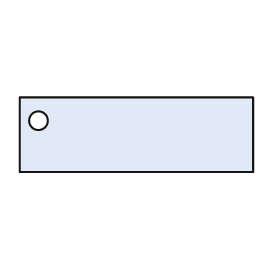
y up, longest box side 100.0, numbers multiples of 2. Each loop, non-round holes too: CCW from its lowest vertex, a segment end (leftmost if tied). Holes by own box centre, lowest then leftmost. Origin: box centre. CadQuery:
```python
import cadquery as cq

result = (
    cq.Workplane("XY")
    .moveTo(-50.0, -16.0)
    .lineTo(50.0, -16.0)
    .lineTo(50.0, 16.0)
    .lineTo(-50.0, 16.0)
    .close()
    .moveTo(-42.0, 6.0)
    .circle(4.0)
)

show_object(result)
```